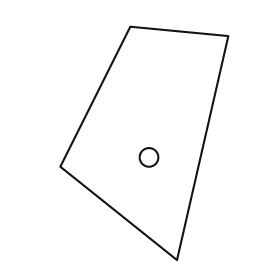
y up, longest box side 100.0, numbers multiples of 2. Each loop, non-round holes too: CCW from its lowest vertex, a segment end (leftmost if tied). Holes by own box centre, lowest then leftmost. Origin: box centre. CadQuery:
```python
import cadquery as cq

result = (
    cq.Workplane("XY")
    .moveTo(14.0, -50.0)
    .lineTo(36.0, 46.0)
    .lineTo(-6.0, 50.0)
    .lineTo(-36.0, -10.0)
    .close()
    .moveTo(2.0, -6.0)
    .circle(4.0)
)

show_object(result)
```